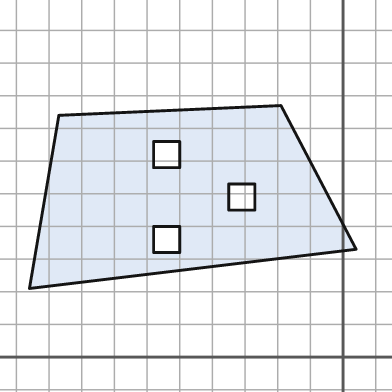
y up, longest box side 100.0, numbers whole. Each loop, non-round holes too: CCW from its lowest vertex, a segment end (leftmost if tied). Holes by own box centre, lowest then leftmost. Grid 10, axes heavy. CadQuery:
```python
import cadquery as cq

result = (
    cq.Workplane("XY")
    .moveTo(-96.0, 21.0)
    .lineTo(4.0, 33.0)
    .lineTo(-19.0, 77.0)
    .lineTo(-87.0, 74.0)
    .close()
    .moveTo(-58.0, 32.0)
    .lineTo(-50.0, 32.0)
    .lineTo(-50.0, 40.0)
    .lineTo(-58.0, 40.0)
    .close()
    .moveTo(-35.0, 45.0)
    .lineTo(-27.0, 45.0)
    .lineTo(-27.0, 53.0)
    .lineTo(-35.0, 53.0)
    .close()
    .moveTo(-58.0, 58.0)
    .lineTo(-50.0, 58.0)
    .lineTo(-50.0, 66.0)
    .lineTo(-58.0, 66.0)
    .close()
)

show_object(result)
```